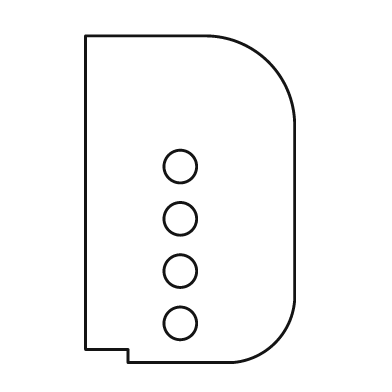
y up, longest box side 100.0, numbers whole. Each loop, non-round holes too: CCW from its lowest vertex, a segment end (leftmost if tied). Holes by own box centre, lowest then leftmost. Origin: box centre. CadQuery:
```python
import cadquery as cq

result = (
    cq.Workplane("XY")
    .moveTo(-19.0, -50.0)
    .lineTo(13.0, -50.0)
    .threePointArc((26.0, -44.0), (32.0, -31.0))
    .lineTo(32.0, 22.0)
    .threePointArc((24.0, 42.0), (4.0, 50.0))
    .lineTo(-32.0, 50.0)
    .lineTo(-32.0, -46.0)
    .lineTo(-19.0, -46.0)
    .close()
    .moveTo(-3.0, -38.0)
    .circle(5.0)
    .moveTo(-3.0, -22.0)
    .circle(5.0)
    .moveTo(-3.0, -6.0)
    .circle(5.0)
    .moveTo(-3.0, 10.0)
    .circle(5.0)
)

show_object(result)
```